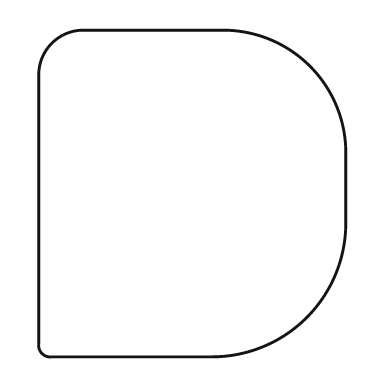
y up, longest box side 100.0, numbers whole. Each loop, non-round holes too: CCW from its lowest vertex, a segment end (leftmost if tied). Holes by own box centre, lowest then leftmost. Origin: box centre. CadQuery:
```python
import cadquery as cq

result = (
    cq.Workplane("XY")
    .moveTo(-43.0, -50.0)
    .lineTo(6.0, -50.0)
    .threePointArc((35.0, -38.0), (47.0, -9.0))
    .lineTo(47.0, 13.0)
    .threePointArc((36.0, 39.0), (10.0, 50.0))
    .lineTo(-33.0, 50.0)
    .threePointArc((-43.0, 46.0), (-47.0, 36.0))
    .lineTo(-47.0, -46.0)
    .threePointArc((-46.0, -49.0), (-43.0, -50.0))
    .close()
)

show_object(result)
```